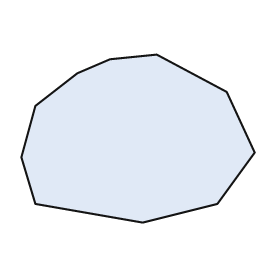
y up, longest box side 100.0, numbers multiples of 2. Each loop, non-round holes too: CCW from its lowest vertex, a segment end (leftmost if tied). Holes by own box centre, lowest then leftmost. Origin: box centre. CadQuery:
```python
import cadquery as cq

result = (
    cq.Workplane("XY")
    .moveTo(2.0, -36.0)
    .lineTo(34.0, -28.0)
    .lineTo(50.0, -6.0)
    .lineTo(38.0, 20.0)
    .lineTo(8.0, 36.0)
    .lineTo(-12.0, 34.0)
    .lineTo(-26.0, 28.0)
    .lineTo(-44.0, 14.0)
    .lineTo(-50.0, -8.0)
    .lineTo(-44.0, -28.0)
    .close()
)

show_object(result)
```